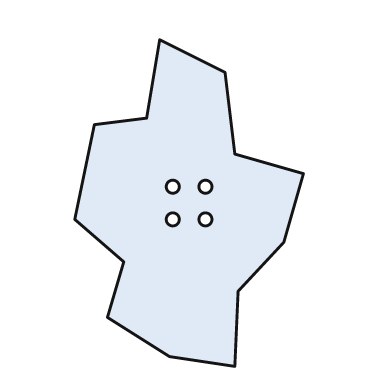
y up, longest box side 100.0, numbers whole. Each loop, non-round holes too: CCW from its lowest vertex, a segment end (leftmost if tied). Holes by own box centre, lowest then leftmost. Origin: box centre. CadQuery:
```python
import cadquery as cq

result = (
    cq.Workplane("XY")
    .moveTo(14.0, -50.0)
    .lineTo(15.0, -27.0)
    .lineTo(29.0, -12.0)
    .lineTo(35.0, 9.0)
    .lineTo(14.0, 15.0)
    .lineTo(11.0, 40.0)
    .lineTo(-9.0, 50.0)
    .lineTo(-13.0, 26.0)
    .lineTo(-29.0, 24.0)
    .lineTo(-35.0, -5.0)
    .lineTo(-20.0, -18.0)
    .lineTo(-25.0, -35.0)
    .lineTo(-6.0, -47.0)
    .close()
    .moveTo(-5.0, -5.0)
    .circle(2.0)
    .moveTo(5.0, -5.0)
    .circle(2.0)
    .moveTo(-5.0, 5.0)
    .circle(2.0)
    .moveTo(5.0, 5.0)
    .circle(2.0)
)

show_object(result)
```